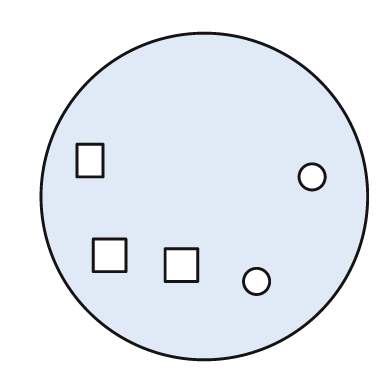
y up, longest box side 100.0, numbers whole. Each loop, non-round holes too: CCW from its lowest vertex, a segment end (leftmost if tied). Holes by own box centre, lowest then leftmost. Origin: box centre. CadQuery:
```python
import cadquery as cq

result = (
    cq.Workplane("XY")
    .moveTo(0.0, 0.0)
    .circle(50.0)
    .moveTo(16.0, -26.0)
    .circle(4.0)
    .moveTo(-12.0, -26.0)
    .lineTo(-2.0, -26.0)
    .lineTo(-2.0, -16.0)
    .lineTo(-12.0, -16.0)
    .close()
    .moveTo(-34.0, -23.0)
    .lineTo(-24.0, -23.0)
    .lineTo(-24.0, -13.0)
    .lineTo(-34.0, -13.0)
    .close()
    .moveTo(33.0, 6.0)
    .circle(4.0)
    .moveTo(-39.0, 6.0)
    .lineTo(-31.0, 6.0)
    .lineTo(-31.0, 16.0)
    .lineTo(-39.0, 16.0)
    .close()
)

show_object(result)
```